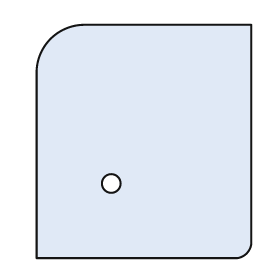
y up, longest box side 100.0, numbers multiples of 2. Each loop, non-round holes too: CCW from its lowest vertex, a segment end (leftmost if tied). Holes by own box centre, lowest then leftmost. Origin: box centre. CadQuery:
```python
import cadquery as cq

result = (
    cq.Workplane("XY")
    .moveTo(-46.0, -50.0)
    .lineTo(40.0, -50.0)
    .threePointArc((44.0, -48.0), (46.0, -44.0))
    .lineTo(46.0, 50.0)
    .lineTo(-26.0, 50.0)
    .threePointArc((-40.0, 44.0), (-46.0, 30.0))
    .close()
    .moveTo(-14.0, -18.0)
    .circle(4.0)
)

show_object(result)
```